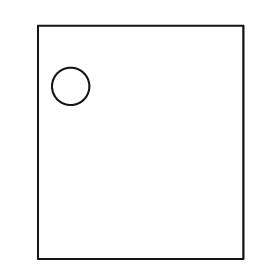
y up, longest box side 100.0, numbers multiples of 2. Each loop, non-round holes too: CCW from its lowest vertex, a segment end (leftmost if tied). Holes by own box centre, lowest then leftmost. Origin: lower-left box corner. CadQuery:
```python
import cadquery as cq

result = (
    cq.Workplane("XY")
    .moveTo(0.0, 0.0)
    .lineTo(88.0, 0.0)
    .lineTo(88.0, 100.0)
    .lineTo(0.0, 100.0)
    .close()
    .moveTo(14.0, 74.0)
    .circle(8.0)
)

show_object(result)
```